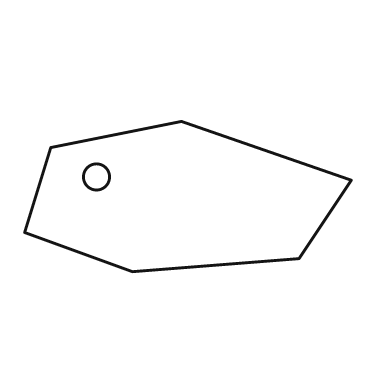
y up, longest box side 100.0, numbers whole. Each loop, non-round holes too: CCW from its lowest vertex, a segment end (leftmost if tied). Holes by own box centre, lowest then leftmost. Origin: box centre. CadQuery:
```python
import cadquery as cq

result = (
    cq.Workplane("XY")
    .moveTo(-17.0, -23.0)
    .lineTo(34.0, -19.0)
    .lineTo(50.0, 5.0)
    .lineTo(-2.0, 23.0)
    .lineTo(-42.0, 15.0)
    .lineTo(-50.0, -11.0)
    .close()
    .moveTo(-28.0, 6.0)
    .circle(4.0)
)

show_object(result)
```